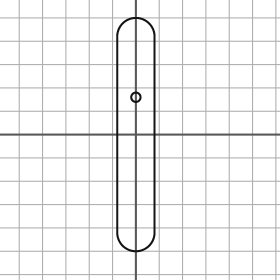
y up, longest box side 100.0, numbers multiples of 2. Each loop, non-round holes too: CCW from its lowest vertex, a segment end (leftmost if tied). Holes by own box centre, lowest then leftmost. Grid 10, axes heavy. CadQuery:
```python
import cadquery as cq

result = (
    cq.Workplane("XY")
    .moveTo(-8.0, -42.0)
    .threePointArc((0.0, -50.0), (8.0, -42.0))
    .lineTo(8.0, 42.0)
    .threePointArc((0.0, 50.0), (-8.0, 42.0))
    .close()
    .moveTo(0.0, 16.0)
    .circle(2.0)
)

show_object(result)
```